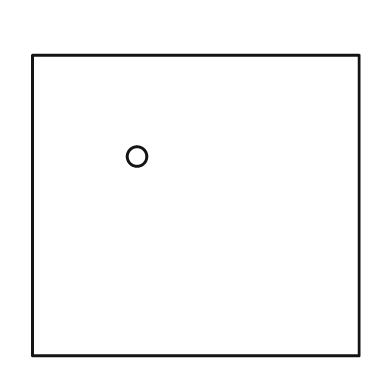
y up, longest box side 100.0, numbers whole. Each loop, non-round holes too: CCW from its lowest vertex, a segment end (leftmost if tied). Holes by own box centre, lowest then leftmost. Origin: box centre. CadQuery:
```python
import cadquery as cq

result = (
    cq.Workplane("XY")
    .moveTo(-50.0, -46.0)
    .lineTo(50.0, -46.0)
    .lineTo(50.0, 46.0)
    .lineTo(-50.0, 46.0)
    .close()
    .moveTo(-18.0, 15.0)
    .circle(3.0)
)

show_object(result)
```